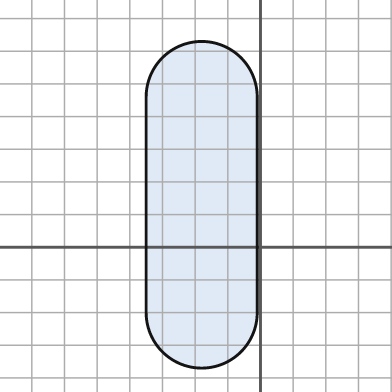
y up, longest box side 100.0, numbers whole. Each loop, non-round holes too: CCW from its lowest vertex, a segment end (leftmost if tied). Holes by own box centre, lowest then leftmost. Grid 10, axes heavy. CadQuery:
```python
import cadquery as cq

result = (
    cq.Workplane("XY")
    .moveTo(-35.0, -20.0)
    .threePointArc((-18.0, -37.0), (-1.0, -20.0))
    .lineTo(-1.0, 46.0)
    .threePointArc((-18.0, 63.0), (-35.0, 46.0))
    .close()
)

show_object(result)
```